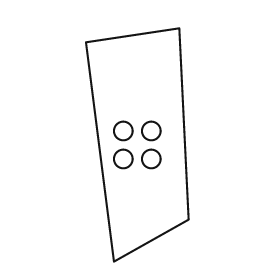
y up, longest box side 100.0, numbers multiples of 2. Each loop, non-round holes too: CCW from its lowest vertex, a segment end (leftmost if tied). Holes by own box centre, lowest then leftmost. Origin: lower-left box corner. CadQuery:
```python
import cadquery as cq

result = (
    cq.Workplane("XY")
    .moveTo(12.0, 0.0)
    .lineTo(44.0, 18.0)
    .lineTo(40.0, 100.0)
    .lineTo(0.0, 94.0)
    .close()
    .moveTo(16.0, 44.0)
    .circle(4.0)
    .moveTo(28.0, 44.0)
    .circle(4.0)
    .moveTo(16.0, 56.0)
    .circle(4.0)
    .moveTo(28.0, 56.0)
    .circle(4.0)
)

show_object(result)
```